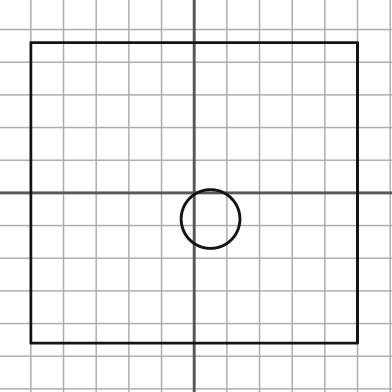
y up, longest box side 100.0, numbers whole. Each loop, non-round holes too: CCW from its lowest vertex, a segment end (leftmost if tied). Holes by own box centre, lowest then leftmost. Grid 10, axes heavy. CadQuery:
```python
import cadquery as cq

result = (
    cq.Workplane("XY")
    .moveTo(-50.0, -46.0)
    .lineTo(50.0, -46.0)
    .lineTo(50.0, 46.0)
    .lineTo(-50.0, 46.0)
    .close()
    .moveTo(5.0, -8.0)
    .circle(9.0)
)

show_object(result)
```